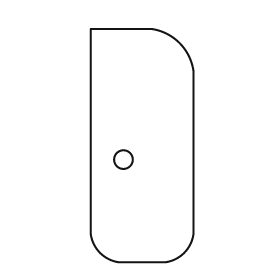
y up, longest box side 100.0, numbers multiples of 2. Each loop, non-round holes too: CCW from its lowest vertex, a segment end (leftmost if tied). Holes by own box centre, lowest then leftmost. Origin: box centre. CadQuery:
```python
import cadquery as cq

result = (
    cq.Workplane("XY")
    .moveTo(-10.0, -50.0)
    .lineTo(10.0, -50.0)
    .threePointArc((18.0, -46.0), (22.0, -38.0))
    .lineTo(22.0, 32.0)
    .threePointArc((16.0, 44.0), (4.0, 50.0))
    .lineTo(-22.0, 50.0)
    .lineTo(-22.0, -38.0)
    .threePointArc((-18.0, -46.0), (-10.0, -50.0))
    .close()
    .moveTo(-8.0, -6.0)
    .circle(4.0)
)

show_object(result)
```